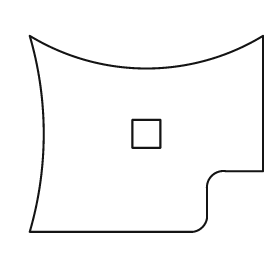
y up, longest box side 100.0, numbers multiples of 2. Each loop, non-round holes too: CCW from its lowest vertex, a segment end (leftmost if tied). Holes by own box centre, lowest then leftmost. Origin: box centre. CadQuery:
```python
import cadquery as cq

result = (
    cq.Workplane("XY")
    .moveTo(-50.0, -42.0)
    .lineTo(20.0, -42.0)
    .threePointArc((24.0, -40.0), (26.0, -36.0))
    .lineTo(26.0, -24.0)
    .threePointArc((28.0, -18.0), (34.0, -16.0))
    .lineTo(50.0, -16.0)
    .lineTo(50.0, 42.0)
    .threePointArc((0.0, 28.0), (-50.0, 42.0))
    .threePointArc((-44.0, 0.0), (-50.0, -42.0))
    .close()
    .moveTo(-6.0, -6.0)
    .lineTo(6.0, -6.0)
    .lineTo(6.0, 6.0)
    .lineTo(-6.0, 6.0)
    .close()
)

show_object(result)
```